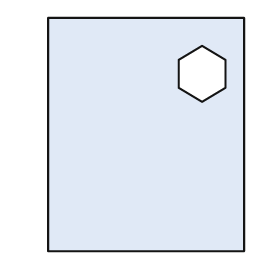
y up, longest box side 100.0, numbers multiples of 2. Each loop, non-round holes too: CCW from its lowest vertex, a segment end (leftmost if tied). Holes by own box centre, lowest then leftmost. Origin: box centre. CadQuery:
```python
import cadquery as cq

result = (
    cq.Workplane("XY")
    .moveTo(-42.0, -50.0)
    .lineTo(42.0, -50.0)
    .lineTo(42.0, 50.0)
    .lineTo(-42.0, 50.0)
    .close()
    .moveTo(24.0, 14.0)
    .lineTo(34.0, 20.0)
    .lineTo(34.0, 32.0)
    .lineTo(24.0, 38.0)
    .lineTo(14.0, 32.0)
    .lineTo(14.0, 20.0)
    .close()
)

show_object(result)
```